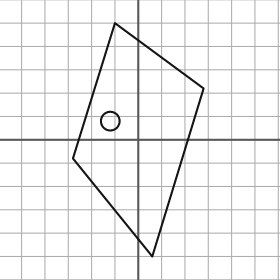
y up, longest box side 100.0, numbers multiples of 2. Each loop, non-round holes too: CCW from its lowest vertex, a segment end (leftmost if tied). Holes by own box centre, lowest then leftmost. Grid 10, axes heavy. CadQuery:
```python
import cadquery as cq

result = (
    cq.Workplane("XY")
    .moveTo(6.0, -50.0)
    .lineTo(28.0, 22.0)
    .lineTo(-10.0, 50.0)
    .lineTo(-28.0, -8.0)
    .close()
    .moveTo(-12.0, 8.0)
    .circle(4.0)
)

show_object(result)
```